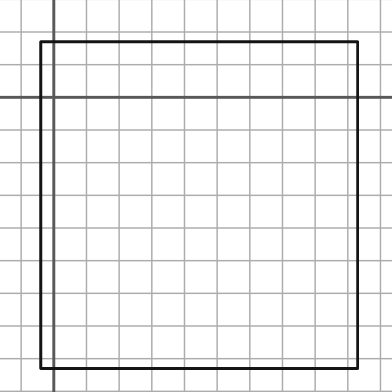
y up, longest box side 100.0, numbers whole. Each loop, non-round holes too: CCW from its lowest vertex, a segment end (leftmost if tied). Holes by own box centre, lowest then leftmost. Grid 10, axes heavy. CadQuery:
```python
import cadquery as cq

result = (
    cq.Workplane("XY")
    .moveTo(-4.0, -83.0)
    .lineTo(93.0, -83.0)
    .lineTo(93.0, 17.0)
    .lineTo(-4.0, 17.0)
    .close()
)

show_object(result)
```